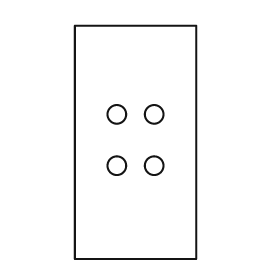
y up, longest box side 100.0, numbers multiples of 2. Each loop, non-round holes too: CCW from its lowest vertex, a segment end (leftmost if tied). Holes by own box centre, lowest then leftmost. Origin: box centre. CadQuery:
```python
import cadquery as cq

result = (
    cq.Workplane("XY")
    .moveTo(-26.0, -50.0)
    .lineTo(26.0, -50.0)
    .lineTo(26.0, 50.0)
    .lineTo(-26.0, 50.0)
    .close()
    .moveTo(-8.0, -10.0)
    .circle(4.0)
    .moveTo(8.0, -10.0)
    .circle(4.0)
    .moveTo(-8.0, 12.0)
    .circle(4.0)
    .moveTo(8.0, 12.0)
    .circle(4.0)
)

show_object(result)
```